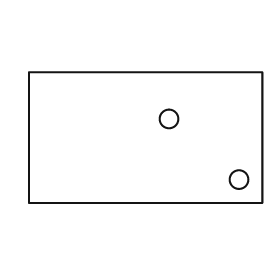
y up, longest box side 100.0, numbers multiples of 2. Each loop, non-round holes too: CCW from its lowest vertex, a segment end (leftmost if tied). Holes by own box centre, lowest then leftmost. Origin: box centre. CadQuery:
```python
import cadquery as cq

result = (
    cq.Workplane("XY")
    .moveTo(-50.0, -28.0)
    .lineTo(50.0, -28.0)
    .lineTo(50.0, 28.0)
    .lineTo(-50.0, 28.0)
    .close()
    .moveTo(40.0, -18.0)
    .circle(4.0)
    .moveTo(10.0, 8.0)
    .circle(4.0)
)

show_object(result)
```